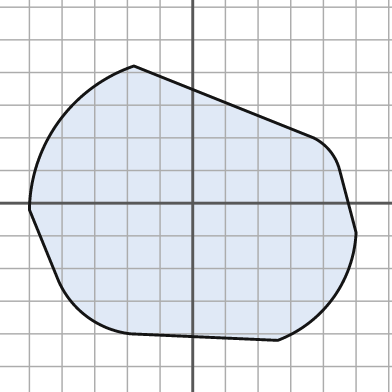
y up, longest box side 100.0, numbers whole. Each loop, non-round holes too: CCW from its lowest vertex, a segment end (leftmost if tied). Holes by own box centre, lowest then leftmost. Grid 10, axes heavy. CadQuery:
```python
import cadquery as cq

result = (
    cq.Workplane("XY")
    .moveTo(26.0, -42.0)
    .threePointArc((43.0, -29.0), (50.0, -9.0))
    .lineTo(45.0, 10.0)
    .threePointArc((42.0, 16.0), (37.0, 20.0))
    .lineTo(-18.0, 42.0)
    .threePointArc((-41.0, 25.0), (-50.0, -2.0))
    .lineTo(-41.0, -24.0)
    .threePointArc((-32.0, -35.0), (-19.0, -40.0))
    .close()
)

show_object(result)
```